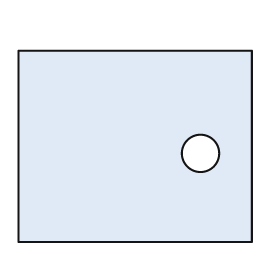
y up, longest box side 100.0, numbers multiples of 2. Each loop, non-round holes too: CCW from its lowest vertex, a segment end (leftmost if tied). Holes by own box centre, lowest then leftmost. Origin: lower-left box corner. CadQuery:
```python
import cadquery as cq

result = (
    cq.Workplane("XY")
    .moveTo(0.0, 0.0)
    .lineTo(100.0, 0.0)
    .lineTo(100.0, 82.0)
    .lineTo(0.0, 82.0)
    .close()
    .moveTo(78.0, 38.0)
    .circle(8.0)
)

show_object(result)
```